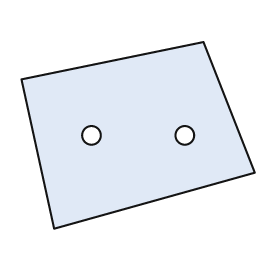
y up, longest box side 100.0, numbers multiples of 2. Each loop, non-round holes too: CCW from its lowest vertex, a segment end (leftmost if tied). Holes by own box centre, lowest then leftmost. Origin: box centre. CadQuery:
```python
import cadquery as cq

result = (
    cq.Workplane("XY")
    .moveTo(-36.0, -40.0)
    .lineTo(50.0, -16.0)
    .lineTo(28.0, 40.0)
    .lineTo(-50.0, 24.0)
    .close()
    .moveTo(-20.0, 0.0)
    .circle(4.0)
    .moveTo(20.0, 0.0)
    .circle(4.0)
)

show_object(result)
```